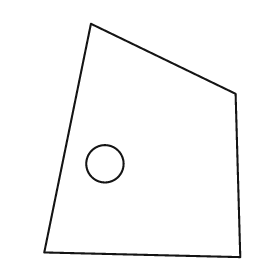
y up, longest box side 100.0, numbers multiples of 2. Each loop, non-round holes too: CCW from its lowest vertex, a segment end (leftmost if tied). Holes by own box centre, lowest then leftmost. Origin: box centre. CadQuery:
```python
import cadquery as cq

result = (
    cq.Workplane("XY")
    .moveTo(42.0, -50.0)
    .lineTo(40.0, 20.0)
    .lineTo(-22.0, 50.0)
    .lineTo(-42.0, -48.0)
    .close()
    .moveTo(-16.0, -10.0)
    .circle(8.0)
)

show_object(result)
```